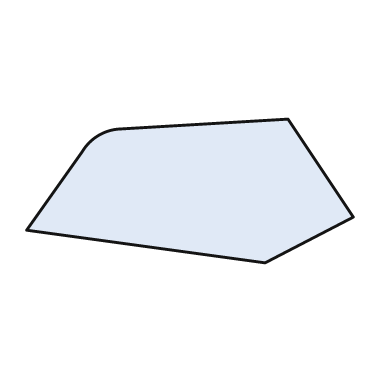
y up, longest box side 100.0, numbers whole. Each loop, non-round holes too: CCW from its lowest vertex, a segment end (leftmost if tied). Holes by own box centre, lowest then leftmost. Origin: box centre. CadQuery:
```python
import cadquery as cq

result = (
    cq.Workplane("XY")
    .moveTo(23.0, -22.0)
    .lineTo(50.0, -8.0)
    .lineTo(30.0, 22.0)
    .lineTo(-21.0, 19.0)
    .threePointArc((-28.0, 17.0), (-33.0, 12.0))
    .lineTo(-50.0, -12.0)
    .close()
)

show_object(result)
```